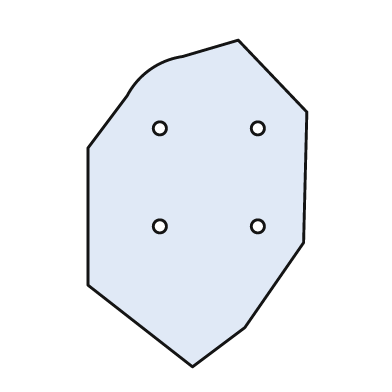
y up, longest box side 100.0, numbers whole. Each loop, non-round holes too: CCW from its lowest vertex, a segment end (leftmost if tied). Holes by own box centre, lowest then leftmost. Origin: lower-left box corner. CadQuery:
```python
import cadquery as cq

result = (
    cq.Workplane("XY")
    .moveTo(32.0, 0.0)
    .lineTo(48.0, 12.0)
    .lineTo(66.0, 38.0)
    .lineTo(67.0, 78.0)
    .lineTo(46.0, 100.0)
    .lineTo(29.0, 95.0)
    .threePointArc((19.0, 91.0), (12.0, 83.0))
    .lineTo(0.0, 67.0)
    .lineTo(0.0, 25.0)
    .close()
    .moveTo(22.0, 43.0)
    .circle(2.0)
    .moveTo(52.0, 43.0)
    .circle(2.0)
    .moveTo(22.0, 73.0)
    .circle(2.0)
    .moveTo(52.0, 73.0)
    .circle(2.0)
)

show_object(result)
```